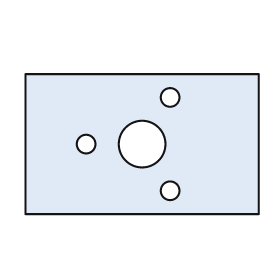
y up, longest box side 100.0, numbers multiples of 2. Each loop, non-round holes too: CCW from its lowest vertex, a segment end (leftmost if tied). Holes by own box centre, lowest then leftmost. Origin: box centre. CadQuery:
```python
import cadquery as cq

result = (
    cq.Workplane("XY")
    .moveTo(-50.0, -30.0)
    .lineTo(50.0, -30.0)
    .lineTo(50.0, 30.0)
    .lineTo(-50.0, 30.0)
    .close()
    .moveTo(12.0, -20.0)
    .circle(4.0)
    .moveTo(-24.0, 0.0)
    .circle(4.0)
    .moveTo(0.0, 0.0)
    .circle(10.0)
    .moveTo(12.0, 20.0)
    .circle(4.0)
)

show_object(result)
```